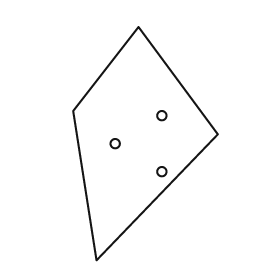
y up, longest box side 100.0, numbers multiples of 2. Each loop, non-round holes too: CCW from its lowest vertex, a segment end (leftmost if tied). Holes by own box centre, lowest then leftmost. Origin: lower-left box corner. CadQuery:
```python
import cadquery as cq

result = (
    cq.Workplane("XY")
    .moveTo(10.0, 0.0)
    .lineTo(62.0, 54.0)
    .lineTo(28.0, 100.0)
    .lineTo(0.0, 64.0)
    .close()
    .moveTo(38.0, 38.0)
    .circle(2.0)
    .moveTo(18.0, 50.0)
    .circle(2.0)
    .moveTo(38.0, 62.0)
    .circle(2.0)
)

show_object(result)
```